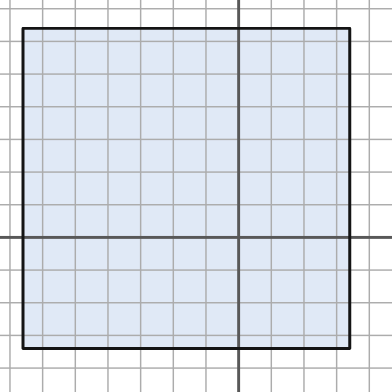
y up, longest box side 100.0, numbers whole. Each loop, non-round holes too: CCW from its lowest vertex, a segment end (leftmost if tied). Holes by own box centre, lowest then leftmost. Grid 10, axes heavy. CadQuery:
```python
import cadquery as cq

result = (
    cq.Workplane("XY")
    .moveTo(-66.0, -34.0)
    .lineTo(34.0, -34.0)
    .lineTo(34.0, 64.0)
    .lineTo(-66.0, 64.0)
    .close()
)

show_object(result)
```